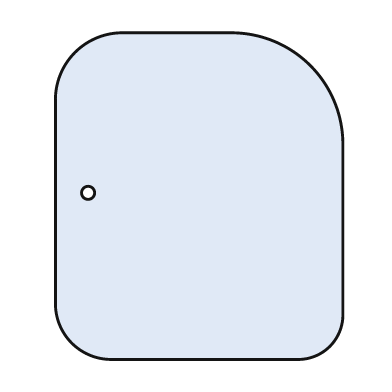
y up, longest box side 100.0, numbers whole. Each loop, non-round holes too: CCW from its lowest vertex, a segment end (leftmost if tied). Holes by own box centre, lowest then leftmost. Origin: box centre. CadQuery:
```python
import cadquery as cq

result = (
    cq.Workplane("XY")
    .moveTo(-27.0, -50.0)
    .lineTo(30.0, -50.0)
    .threePointArc((40.0, -46.0), (44.0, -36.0))
    .lineTo(44.0, 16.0)
    .threePointArc((34.0, 40.0), (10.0, 50.0))
    .lineTo(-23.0, 50.0)
    .threePointArc((-38.0, 44.0), (-44.0, 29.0))
    .lineTo(-44.0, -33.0)
    .threePointArc((-39.0, -45.0), (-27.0, -50.0))
    .close()
    .moveTo(-34.0, 1.0)
    .circle(2.0)
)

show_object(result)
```